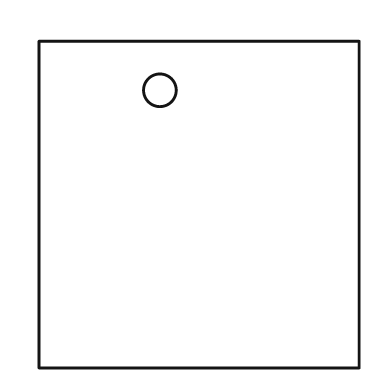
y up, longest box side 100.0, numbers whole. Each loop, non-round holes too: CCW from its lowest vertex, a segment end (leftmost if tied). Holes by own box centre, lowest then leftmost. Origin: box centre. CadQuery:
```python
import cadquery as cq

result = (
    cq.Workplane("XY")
    .moveTo(-49.0, -50.0)
    .lineTo(49.0, -50.0)
    .lineTo(49.0, 50.0)
    .lineTo(-49.0, 50.0)
    .close()
    .moveTo(-12.0, 35.0)
    .circle(5.0)
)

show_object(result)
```